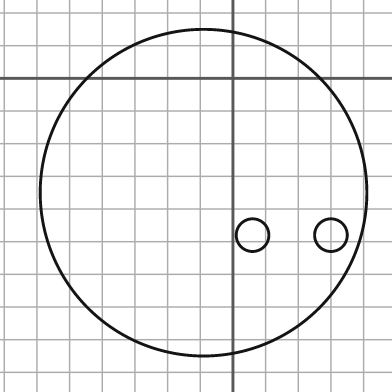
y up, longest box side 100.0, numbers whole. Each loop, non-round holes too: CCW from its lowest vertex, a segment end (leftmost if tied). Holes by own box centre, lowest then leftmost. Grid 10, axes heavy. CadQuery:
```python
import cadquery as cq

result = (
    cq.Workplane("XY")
    .moveTo(-9.0, -35.0)
    .circle(50.0)
    .moveTo(6.0, -48.0)
    .circle(5.0)
    .moveTo(30.0, -48.0)
    .circle(5.0)
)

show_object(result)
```